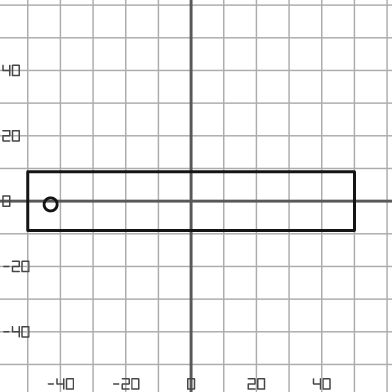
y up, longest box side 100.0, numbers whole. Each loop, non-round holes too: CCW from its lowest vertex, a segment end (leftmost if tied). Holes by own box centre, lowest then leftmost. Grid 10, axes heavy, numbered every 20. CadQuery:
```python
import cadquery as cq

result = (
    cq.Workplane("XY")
    .moveTo(-50.0, -9.0)
    .lineTo(50.0, -9.0)
    .lineTo(50.0, 9.0)
    .lineTo(-50.0, 9.0)
    .close()
    .moveTo(-43.0, -1.0)
    .circle(2.0)
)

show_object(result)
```